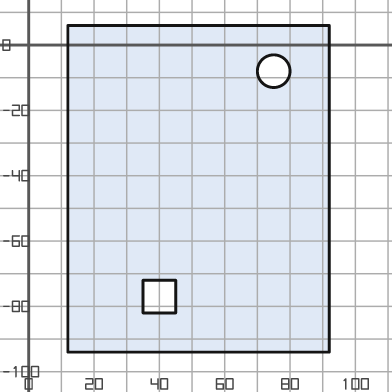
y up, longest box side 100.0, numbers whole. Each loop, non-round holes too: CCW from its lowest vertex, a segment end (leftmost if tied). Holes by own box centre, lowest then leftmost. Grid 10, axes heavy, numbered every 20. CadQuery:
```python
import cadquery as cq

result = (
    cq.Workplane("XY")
    .moveTo(12.0, -94.0)
    .lineTo(92.0, -94.0)
    .lineTo(92.0, 6.0)
    .lineTo(12.0, 6.0)
    .close()
    .moveTo(35.0, -82.0)
    .lineTo(45.0, -82.0)
    .lineTo(45.0, -72.0)
    .lineTo(35.0, -72.0)
    .close()
    .moveTo(75.0, -8.0)
    .circle(5.0)
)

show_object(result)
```